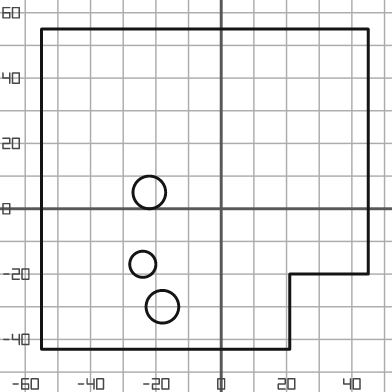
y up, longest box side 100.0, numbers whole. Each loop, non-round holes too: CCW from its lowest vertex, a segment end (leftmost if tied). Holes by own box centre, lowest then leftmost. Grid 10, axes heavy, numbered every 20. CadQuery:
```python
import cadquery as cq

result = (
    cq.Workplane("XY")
    .moveTo(-55.0, -43.0)
    .lineTo(21.0, -43.0)
    .lineTo(21.0, -20.0)
    .lineTo(45.0, -20.0)
    .lineTo(45.0, 55.0)
    .lineTo(-55.0, 55.0)
    .close()
    .moveTo(-18.0, -30.0)
    .circle(5.0)
    .moveTo(-24.0, -17.0)
    .circle(4.0)
    .moveTo(-22.0, 5.0)
    .circle(5.0)
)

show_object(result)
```